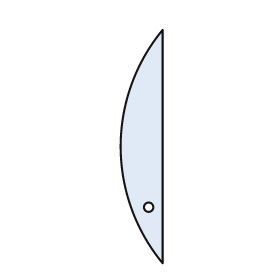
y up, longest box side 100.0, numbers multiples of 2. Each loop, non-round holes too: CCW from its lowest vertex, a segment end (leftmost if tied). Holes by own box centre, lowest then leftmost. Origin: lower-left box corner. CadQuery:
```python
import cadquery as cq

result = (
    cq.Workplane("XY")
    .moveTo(18.0, 0.0)
    .lineTo(18.0, 100.0)
    .threePointArc((0.0, 50.0), (18.0, 0.0))
    .close()
    .moveTo(12.0, 24.0)
    .circle(2.0)
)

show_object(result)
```